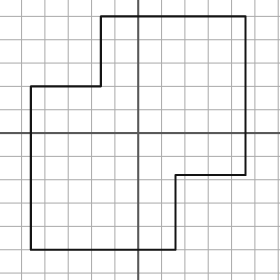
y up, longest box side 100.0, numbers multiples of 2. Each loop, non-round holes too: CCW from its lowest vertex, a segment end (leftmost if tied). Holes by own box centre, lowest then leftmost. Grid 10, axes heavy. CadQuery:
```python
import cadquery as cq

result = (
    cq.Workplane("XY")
    .moveTo(-46.0, -50.0)
    .lineTo(16.0, -50.0)
    .lineTo(16.0, -18.0)
    .lineTo(46.0, -18.0)
    .lineTo(46.0, 50.0)
    .lineTo(-16.0, 50.0)
    .lineTo(-16.0, 20.0)
    .lineTo(-46.0, 20.0)
    .close()
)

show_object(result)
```